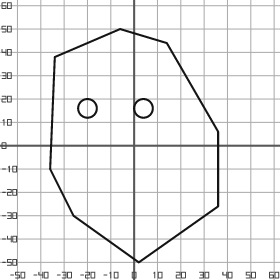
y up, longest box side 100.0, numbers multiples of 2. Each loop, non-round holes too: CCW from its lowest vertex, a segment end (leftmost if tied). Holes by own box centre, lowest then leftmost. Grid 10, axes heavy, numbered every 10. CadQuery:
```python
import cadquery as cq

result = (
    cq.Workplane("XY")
    .moveTo(2.0, -50.0)
    .lineTo(36.0, -26.0)
    .lineTo(36.0, 6.0)
    .lineTo(14.0, 44.0)
    .lineTo(-6.0, 50.0)
    .lineTo(-34.0, 38.0)
    .lineTo(-36.0, -10.0)
    .lineTo(-26.0, -30.0)
    .close()
    .moveTo(-20.0, 16.0)
    .circle(4.0)
    .moveTo(4.0, 16.0)
    .circle(4.0)
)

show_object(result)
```